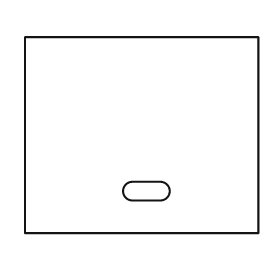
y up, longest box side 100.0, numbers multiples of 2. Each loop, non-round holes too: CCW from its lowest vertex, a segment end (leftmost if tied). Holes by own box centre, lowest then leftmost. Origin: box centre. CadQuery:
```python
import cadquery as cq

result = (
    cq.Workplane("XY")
    .moveTo(-50.0, -42.0)
    .lineTo(50.0, -42.0)
    .lineTo(50.0, 42.0)
    .lineTo(-50.0, 42.0)
    .close()
    .moveTo(-4.0, -28.0)
    .lineTo(8.0, -28.0)
    .threePointArc((12.0, -24.0), (8.0, -20.0))
    .lineTo(-4.0, -20.0)
    .threePointArc((-8.0, -24.0), (-4.0, -28.0))
    .close()
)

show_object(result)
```